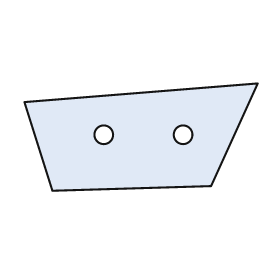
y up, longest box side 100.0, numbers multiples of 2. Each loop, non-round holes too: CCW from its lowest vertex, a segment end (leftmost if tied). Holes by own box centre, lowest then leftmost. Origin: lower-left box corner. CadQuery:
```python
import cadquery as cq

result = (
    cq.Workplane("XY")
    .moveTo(12.0, 0.0)
    .lineTo(80.0, 2.0)
    .lineTo(100.0, 46.0)
    .lineTo(0.0, 38.0)
    .close()
    .moveTo(34.0, 24.0)
    .circle(4.0)
    .moveTo(68.0, 24.0)
    .circle(4.0)
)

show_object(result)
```